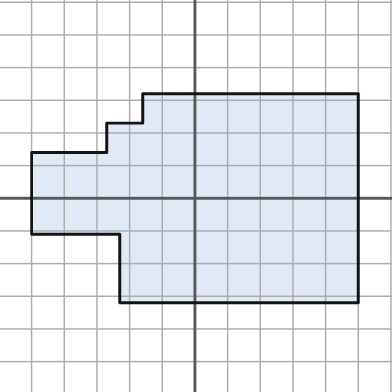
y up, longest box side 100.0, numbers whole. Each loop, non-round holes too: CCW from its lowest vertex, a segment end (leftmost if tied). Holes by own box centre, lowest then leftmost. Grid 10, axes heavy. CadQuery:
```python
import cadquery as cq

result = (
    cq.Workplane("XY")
    .moveTo(-23.0, -32.0)
    .lineTo(50.0, -32.0)
    .lineTo(50.0, 32.0)
    .lineTo(-16.0, 32.0)
    .lineTo(-16.0, 23.0)
    .lineTo(-27.0, 23.0)
    .lineTo(-27.0, 14.0)
    .lineTo(-50.0, 14.0)
    .lineTo(-50.0, -11.0)
    .lineTo(-23.0, -11.0)
    .close()
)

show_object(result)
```